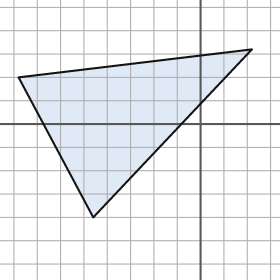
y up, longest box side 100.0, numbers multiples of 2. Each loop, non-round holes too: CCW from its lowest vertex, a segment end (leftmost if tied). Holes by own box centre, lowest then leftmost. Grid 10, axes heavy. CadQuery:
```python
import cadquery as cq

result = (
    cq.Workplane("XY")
    .moveTo(-46.0, -40.0)
    .lineTo(22.0, 32.0)
    .lineTo(-78.0, 20.0)
    .close()
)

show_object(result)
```